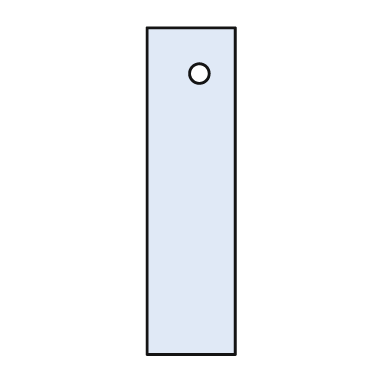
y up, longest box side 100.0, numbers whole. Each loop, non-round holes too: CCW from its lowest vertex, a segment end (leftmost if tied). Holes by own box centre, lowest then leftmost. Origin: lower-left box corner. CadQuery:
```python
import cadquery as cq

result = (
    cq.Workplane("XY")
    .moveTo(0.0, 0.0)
    .lineTo(27.0, 0.0)
    .lineTo(27.0, 100.0)
    .lineTo(0.0, 100.0)
    .close()
    .moveTo(16.0, 86.0)
    .circle(3.0)
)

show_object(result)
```